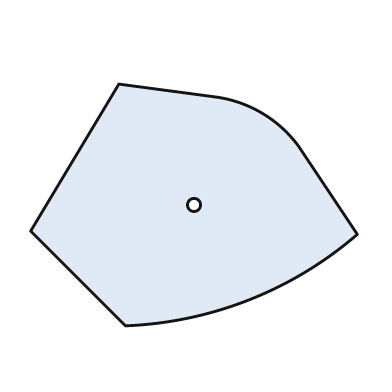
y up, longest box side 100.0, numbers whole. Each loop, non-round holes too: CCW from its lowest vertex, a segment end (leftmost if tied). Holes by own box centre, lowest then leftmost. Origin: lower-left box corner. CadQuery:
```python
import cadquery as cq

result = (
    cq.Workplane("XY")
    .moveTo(29.0, 0.0)
    .threePointArc((67.0, 8.0), (100.0, 28.0))
    .lineTo(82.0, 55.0)
    .threePointArc((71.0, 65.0), (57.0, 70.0))
    .lineTo(27.0, 74.0)
    .lineTo(0.0, 29.0)
    .close()
    .moveTo(50.0, 37.0)
    .circle(2.0)
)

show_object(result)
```